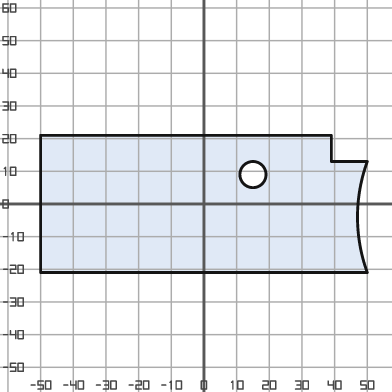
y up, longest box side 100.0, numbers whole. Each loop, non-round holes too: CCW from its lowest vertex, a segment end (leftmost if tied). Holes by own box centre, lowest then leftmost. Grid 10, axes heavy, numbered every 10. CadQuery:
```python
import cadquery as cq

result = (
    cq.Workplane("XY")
    .moveTo(-50.0, -21.0)
    .lineTo(50.0, -21.0)
    .threePointArc((47.0, -4.0), (50.0, 13.0))
    .lineTo(39.0, 13.0)
    .lineTo(39.0, 21.0)
    .lineTo(-50.0, 21.0)
    .close()
    .moveTo(15.0, 9.0)
    .circle(4.0)
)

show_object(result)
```